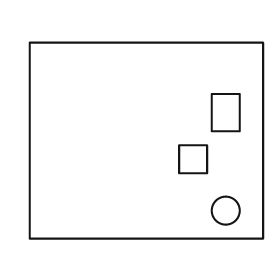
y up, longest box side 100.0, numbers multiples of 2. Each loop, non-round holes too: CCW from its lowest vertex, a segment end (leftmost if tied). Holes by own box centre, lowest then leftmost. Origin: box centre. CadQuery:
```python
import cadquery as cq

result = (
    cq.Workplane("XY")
    .moveTo(-50.0, -42.0)
    .lineTo(50.0, -42.0)
    .lineTo(50.0, 42.0)
    .lineTo(-50.0, 42.0)
    .close()
    .moveTo(34.0, -30.0)
    .circle(6.0)
    .moveTo(14.0, -14.0)
    .lineTo(26.0, -14.0)
    .lineTo(26.0, -2.0)
    .lineTo(14.0, -2.0)
    .close()
    .moveTo(28.0, 4.0)
    .lineTo(40.0, 4.0)
    .lineTo(40.0, 20.0)
    .lineTo(28.0, 20.0)
    .close()
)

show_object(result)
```